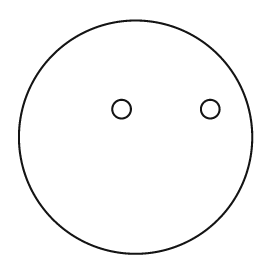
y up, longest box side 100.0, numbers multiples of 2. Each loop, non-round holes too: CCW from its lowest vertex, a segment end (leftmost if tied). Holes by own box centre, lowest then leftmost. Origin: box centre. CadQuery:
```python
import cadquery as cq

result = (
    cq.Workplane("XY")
    .moveTo(0.0, 0.0)
    .circle(50.0)
    .moveTo(-6.0, 12.0)
    .circle(4.0)
    .moveTo(32.0, 12.0)
    .circle(4.0)
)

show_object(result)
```